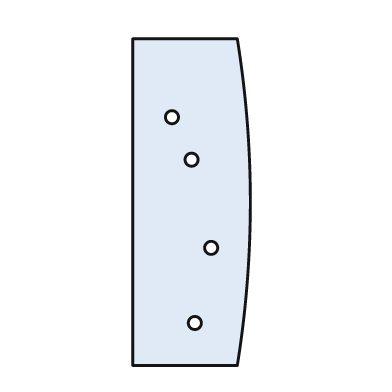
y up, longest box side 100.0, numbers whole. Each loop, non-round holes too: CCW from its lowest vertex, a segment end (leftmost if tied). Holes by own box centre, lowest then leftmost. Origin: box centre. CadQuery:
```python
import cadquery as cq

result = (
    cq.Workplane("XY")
    .moveTo(-18.0, -50.0)
    .lineTo(14.0, -50.0)
    .threePointArc((18.0, 0.0), (14.0, 50.0))
    .lineTo(-18.0, 50.0)
    .close()
    .moveTo(1.0, -37.0)
    .circle(2.0)
    .moveTo(6.0, -14.0)
    .circle(2.0)
    .moveTo(0.0, 13.0)
    .circle(2.0)
    .moveTo(-6.0, 26.0)
    .circle(2.0)
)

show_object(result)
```